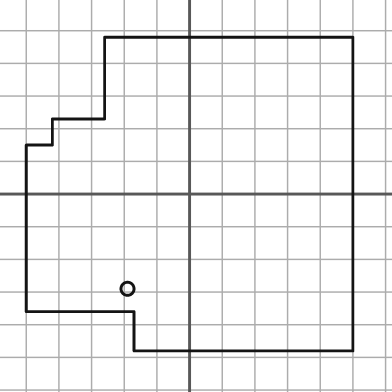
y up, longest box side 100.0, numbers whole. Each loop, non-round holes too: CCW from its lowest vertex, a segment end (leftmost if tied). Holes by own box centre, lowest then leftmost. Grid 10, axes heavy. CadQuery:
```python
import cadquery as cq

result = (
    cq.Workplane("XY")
    .moveTo(-17.0, -48.0)
    .lineTo(50.0, -48.0)
    .lineTo(50.0, 48.0)
    .lineTo(-26.0, 48.0)
    .lineTo(-26.0, 23.0)
    .lineTo(-42.0, 23.0)
    .lineTo(-42.0, 15.0)
    .lineTo(-50.0, 15.0)
    .lineTo(-50.0, -36.0)
    .lineTo(-17.0, -36.0)
    .close()
    .moveTo(-19.0, -29.0)
    .circle(2.0)
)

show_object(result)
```